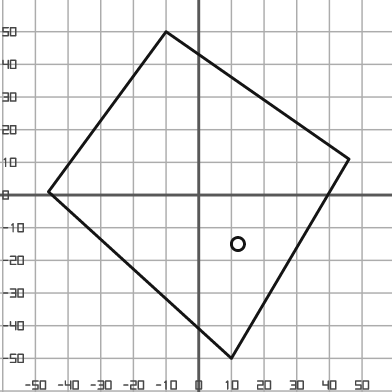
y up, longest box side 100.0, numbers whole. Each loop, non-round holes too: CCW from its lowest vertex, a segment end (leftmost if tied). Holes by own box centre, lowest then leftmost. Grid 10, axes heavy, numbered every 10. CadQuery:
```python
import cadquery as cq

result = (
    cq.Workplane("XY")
    .moveTo(10.0, -50.0)
    .lineTo(46.0, 11.0)
    .lineTo(-10.0, 50.0)
    .lineTo(-46.0, 1.0)
    .close()
    .moveTo(12.0, -15.0)
    .circle(2.0)
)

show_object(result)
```